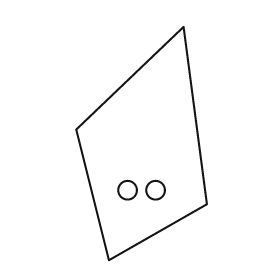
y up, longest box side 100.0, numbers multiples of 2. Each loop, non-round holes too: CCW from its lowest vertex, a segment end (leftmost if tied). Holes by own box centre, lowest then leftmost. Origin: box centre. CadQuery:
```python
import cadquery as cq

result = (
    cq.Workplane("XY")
    .moveTo(-14.0, -50.0)
    .lineTo(28.0, -26.0)
    .lineTo(18.0, 50.0)
    .lineTo(-28.0, 6.0)
    .close()
    .moveTo(-6.0, -20.0)
    .circle(4.0)
    .moveTo(6.0, -20.0)
    .circle(4.0)
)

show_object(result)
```